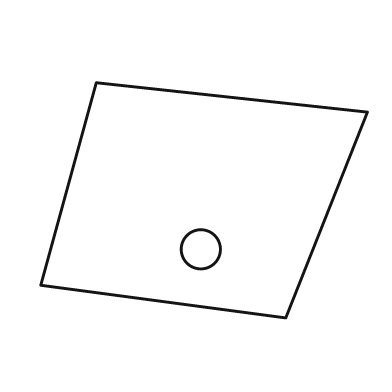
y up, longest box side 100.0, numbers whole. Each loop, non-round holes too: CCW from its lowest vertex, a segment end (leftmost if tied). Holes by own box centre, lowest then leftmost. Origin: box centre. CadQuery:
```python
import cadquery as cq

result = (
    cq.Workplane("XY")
    .moveTo(25.0, -36.0)
    .lineTo(50.0, 27.0)
    .lineTo(-33.0, 36.0)
    .lineTo(-50.0, -26.0)
    .close()
    .moveTo(-1.0, -15.0)
    .circle(6.0)
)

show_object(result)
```